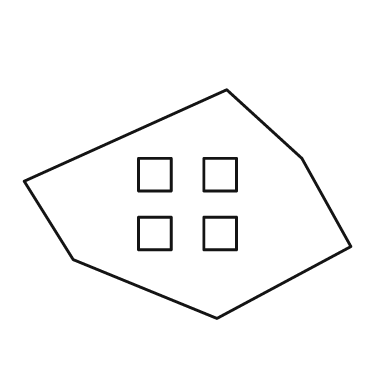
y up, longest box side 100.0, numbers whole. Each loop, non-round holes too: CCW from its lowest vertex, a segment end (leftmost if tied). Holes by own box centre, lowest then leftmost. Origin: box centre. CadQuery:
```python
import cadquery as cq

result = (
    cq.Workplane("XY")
    .moveTo(9.0, -35.0)
    .lineTo(50.0, -13.0)
    .lineTo(35.0, 14.0)
    .lineTo(12.0, 35.0)
    .lineTo(-50.0, 7.0)
    .lineTo(-35.0, -17.0)
    .close()
    .moveTo(-15.0, -14.0)
    .lineTo(-5.0, -14.0)
    .lineTo(-5.0, -4.0)
    .lineTo(-15.0, -4.0)
    .close()
    .moveTo(5.0, -14.0)
    .lineTo(15.0, -14.0)
    .lineTo(15.0, -4.0)
    .lineTo(5.0, -4.0)
    .close()
    .moveTo(-15.0, 4.0)
    .lineTo(-5.0, 4.0)
    .lineTo(-5.0, 14.0)
    .lineTo(-15.0, 14.0)
    .close()
    .moveTo(5.0, 4.0)
    .lineTo(15.0, 4.0)
    .lineTo(15.0, 14.0)
    .lineTo(5.0, 14.0)
    .close()
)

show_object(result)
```